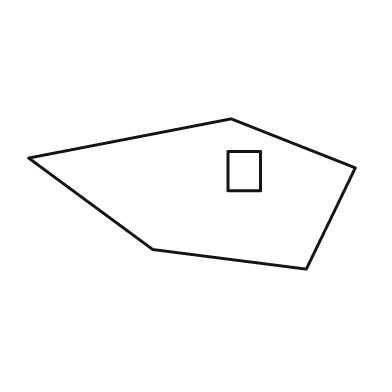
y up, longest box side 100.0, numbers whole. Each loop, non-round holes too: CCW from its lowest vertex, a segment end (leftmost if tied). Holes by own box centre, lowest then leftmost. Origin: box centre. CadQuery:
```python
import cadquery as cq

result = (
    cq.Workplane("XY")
    .moveTo(35.0, -23.0)
    .lineTo(50.0, 8.0)
    .lineTo(12.0, 23.0)
    .lineTo(-50.0, 11.0)
    .lineTo(-12.0, -17.0)
    .close()
    .moveTo(11.0, 1.0)
    .lineTo(21.0, 1.0)
    .lineTo(21.0, 13.0)
    .lineTo(11.0, 13.0)
    .close()
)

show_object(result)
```